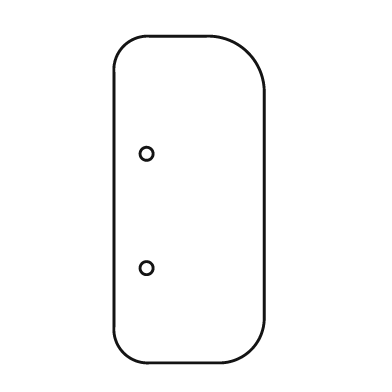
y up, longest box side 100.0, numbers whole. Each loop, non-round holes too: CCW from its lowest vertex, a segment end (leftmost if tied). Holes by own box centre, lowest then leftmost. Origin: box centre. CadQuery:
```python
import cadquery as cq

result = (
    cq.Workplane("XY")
    .moveTo(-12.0, -50.0)
    .lineTo(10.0, -50.0)
    .threePointArc((19.0, -46.0), (23.0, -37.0))
    .lineTo(23.0, 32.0)
    .threePointArc((18.0, 45.0), (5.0, 50.0))
    .lineTo(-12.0, 50.0)
    .threePointArc((-20.0, 47.0), (-23.0, 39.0))
    .lineTo(-23.0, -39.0)
    .threePointArc((-20.0, -47.0), (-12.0, -50.0))
    .close()
    .moveTo(-13.0, -21.0)
    .circle(2.0)
    .moveTo(-13.0, 14.0)
    .circle(2.0)
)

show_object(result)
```